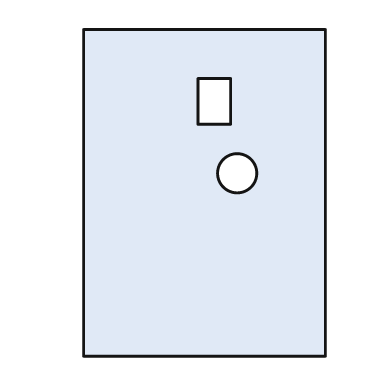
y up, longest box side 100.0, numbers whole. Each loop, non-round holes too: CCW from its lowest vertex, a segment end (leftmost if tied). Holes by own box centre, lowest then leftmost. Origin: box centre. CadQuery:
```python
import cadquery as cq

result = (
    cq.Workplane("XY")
    .moveTo(-37.0, -50.0)
    .lineTo(37.0, -50.0)
    .lineTo(37.0, 50.0)
    .lineTo(-37.0, 50.0)
    .close()
    .moveTo(10.0, 6.0)
    .circle(6.0)
    .moveTo(-2.0, 21.0)
    .lineTo(8.0, 21.0)
    .lineTo(8.0, 35.0)
    .lineTo(-2.0, 35.0)
    .close()
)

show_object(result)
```